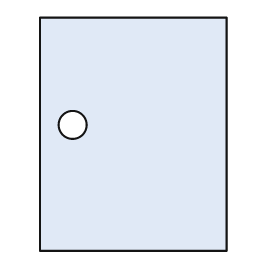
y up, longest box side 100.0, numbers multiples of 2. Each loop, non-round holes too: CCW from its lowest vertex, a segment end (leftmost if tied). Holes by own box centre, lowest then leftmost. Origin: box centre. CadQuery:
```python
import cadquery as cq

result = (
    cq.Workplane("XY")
    .moveTo(-40.0, -50.0)
    .lineTo(40.0, -50.0)
    .lineTo(40.0, 50.0)
    .lineTo(-40.0, 50.0)
    .close()
    .moveTo(-26.0, 4.0)
    .circle(6.0)
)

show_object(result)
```